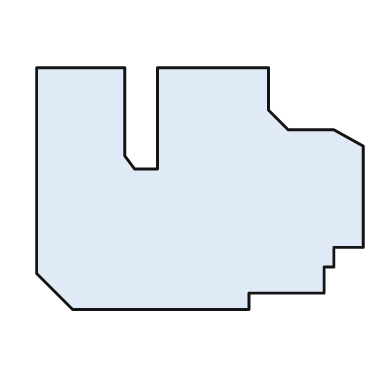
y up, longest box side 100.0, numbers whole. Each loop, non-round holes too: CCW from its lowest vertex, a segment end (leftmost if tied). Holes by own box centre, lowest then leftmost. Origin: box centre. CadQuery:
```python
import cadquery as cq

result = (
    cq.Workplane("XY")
    .moveTo(-39.0, -37.0)
    .lineTo(15.0, -37.0)
    .lineTo(15.0, -32.0)
    .lineTo(38.0, -32.0)
    .lineTo(38.0, -24.0)
    .lineTo(41.0, -24.0)
    .lineTo(41.0, -18.0)
    .lineTo(50.0, -18.0)
    .lineTo(50.0, 13.0)
    .lineTo(41.0, 18.0)
    .lineTo(27.0, 18.0)
    .lineTo(21.0, 24.0)
    .lineTo(21.0, 37.0)
    .lineTo(-13.0, 37.0)
    .lineTo(-13.0, 6.0)
    .lineTo(-20.0, 6.0)
    .lineTo(-23.0, 10.0)
    .lineTo(-23.0, 37.0)
    .lineTo(-50.0, 37.0)
    .lineTo(-50.0, -26.0)
    .close()
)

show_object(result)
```